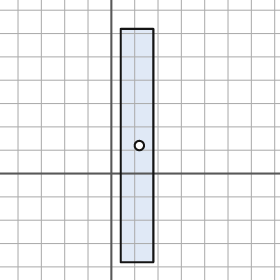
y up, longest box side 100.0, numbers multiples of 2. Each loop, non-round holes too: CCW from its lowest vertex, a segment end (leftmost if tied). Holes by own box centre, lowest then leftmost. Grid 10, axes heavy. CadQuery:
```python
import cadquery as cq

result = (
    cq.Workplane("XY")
    .moveTo(4.0, -38.0)
    .lineTo(18.0, -38.0)
    .lineTo(18.0, 62.0)
    .lineTo(4.0, 62.0)
    .close()
    .moveTo(12.0, 12.0)
    .circle(2.0)
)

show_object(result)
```